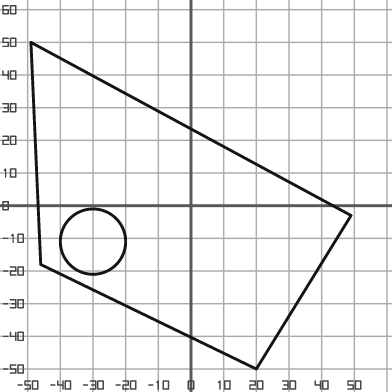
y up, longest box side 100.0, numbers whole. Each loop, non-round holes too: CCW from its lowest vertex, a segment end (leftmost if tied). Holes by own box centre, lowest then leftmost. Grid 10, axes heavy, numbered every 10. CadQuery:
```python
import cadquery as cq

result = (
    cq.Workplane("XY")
    .moveTo(20.0, -50.0)
    .lineTo(49.0, -3.0)
    .lineTo(-49.0, 50.0)
    .lineTo(-46.0, -18.0)
    .close()
    .moveTo(-30.0, -11.0)
    .circle(10.0)
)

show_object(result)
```